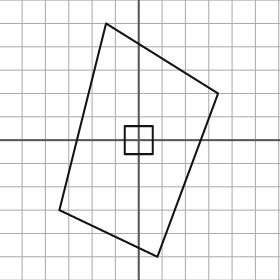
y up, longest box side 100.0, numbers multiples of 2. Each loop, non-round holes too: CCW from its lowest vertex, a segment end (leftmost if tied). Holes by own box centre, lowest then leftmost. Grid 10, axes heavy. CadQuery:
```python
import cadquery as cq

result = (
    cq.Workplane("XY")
    .moveTo(8.0, -50.0)
    .lineTo(34.0, 20.0)
    .lineTo(-14.0, 50.0)
    .lineTo(-34.0, -30.0)
    .close()
    .moveTo(-6.0, -6.0)
    .lineTo(6.0, -6.0)
    .lineTo(6.0, 6.0)
    .lineTo(-6.0, 6.0)
    .close()
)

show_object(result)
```